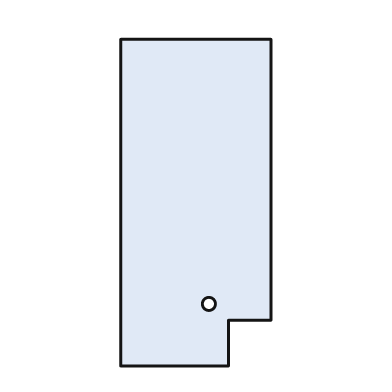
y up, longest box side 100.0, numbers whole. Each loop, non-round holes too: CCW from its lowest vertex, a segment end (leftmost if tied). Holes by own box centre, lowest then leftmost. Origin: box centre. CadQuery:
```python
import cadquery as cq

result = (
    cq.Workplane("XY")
    .moveTo(-23.0, -50.0)
    .lineTo(10.0, -50.0)
    .lineTo(10.0, -36.0)
    .lineTo(23.0, -36.0)
    .lineTo(23.0, 50.0)
    .lineTo(-23.0, 50.0)
    .close()
    .moveTo(4.0, -31.0)
    .circle(2.0)
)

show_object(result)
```